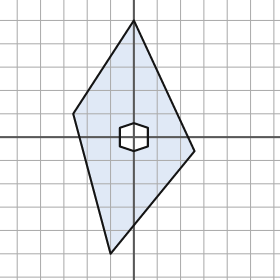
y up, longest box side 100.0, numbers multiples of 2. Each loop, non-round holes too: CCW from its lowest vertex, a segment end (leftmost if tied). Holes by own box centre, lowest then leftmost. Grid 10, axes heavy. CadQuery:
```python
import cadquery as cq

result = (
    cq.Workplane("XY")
    .moveTo(-10.0, -50.0)
    .lineTo(26.0, -6.0)
    .lineTo(0.0, 50.0)
    .lineTo(-26.0, 10.0)
    .close()
    .moveTo(0.0, -6.0)
    .lineTo(6.0, -4.0)
    .lineTo(6.0, 4.0)
    .lineTo(0.0, 6.0)
    .lineTo(-6.0, 4.0)
    .lineTo(-6.0, -4.0)
    .close()
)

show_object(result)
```